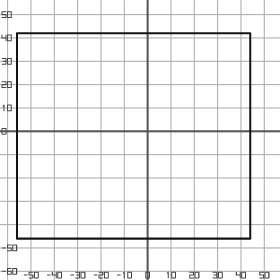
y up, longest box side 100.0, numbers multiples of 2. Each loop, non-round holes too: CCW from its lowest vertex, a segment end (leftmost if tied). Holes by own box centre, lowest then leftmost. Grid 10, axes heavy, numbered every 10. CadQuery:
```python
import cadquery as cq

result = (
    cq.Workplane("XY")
    .moveTo(-56.0, -46.0)
    .lineTo(44.0, -46.0)
    .lineTo(44.0, 42.0)
    .lineTo(-56.0, 42.0)
    .close()
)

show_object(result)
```